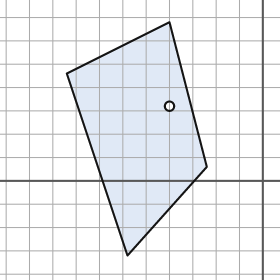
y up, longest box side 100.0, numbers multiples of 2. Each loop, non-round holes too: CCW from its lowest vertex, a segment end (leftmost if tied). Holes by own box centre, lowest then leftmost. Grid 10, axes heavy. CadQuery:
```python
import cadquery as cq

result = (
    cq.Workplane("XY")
    .moveTo(-58.0, -32.0)
    .lineTo(-24.0, 6.0)
    .lineTo(-40.0, 68.0)
    .lineTo(-84.0, 46.0)
    .close()
    .moveTo(-40.0, 32.0)
    .circle(2.0)
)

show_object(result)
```